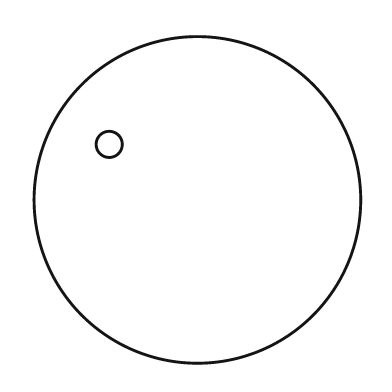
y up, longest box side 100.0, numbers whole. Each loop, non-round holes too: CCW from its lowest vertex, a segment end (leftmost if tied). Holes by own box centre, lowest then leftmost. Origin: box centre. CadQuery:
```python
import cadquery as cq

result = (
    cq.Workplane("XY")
    .moveTo(0.0, 0.0)
    .circle(50.0)
    .moveTo(-27.0, 17.0)
    .circle(4.0)
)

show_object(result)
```